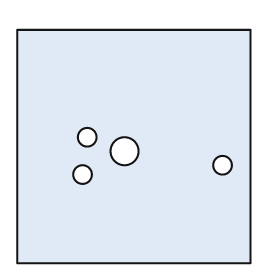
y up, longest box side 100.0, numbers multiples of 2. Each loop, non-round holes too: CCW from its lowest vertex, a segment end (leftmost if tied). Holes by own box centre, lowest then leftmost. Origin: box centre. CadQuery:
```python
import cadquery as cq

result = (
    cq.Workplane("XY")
    .moveTo(-50.0, -50.0)
    .lineTo(50.0, -50.0)
    .lineTo(50.0, 50.0)
    .lineTo(-50.0, 50.0)
    .close()
    .moveTo(-22.0, -12.0)
    .circle(4.0)
    .moveTo(38.0, -8.0)
    .circle(4.0)
    .moveTo(-4.0, -2.0)
    .circle(6.0)
    .moveTo(-20.0, 4.0)
    .circle(4.0)
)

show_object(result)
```